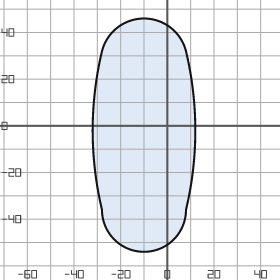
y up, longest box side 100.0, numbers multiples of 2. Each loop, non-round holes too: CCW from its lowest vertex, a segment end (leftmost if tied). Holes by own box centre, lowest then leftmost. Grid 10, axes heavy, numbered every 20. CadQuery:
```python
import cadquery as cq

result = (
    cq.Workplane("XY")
    .moveTo(-28.0, -36.0)
    .threePointArc((-10.0, -54.0), (8.0, -36.0))
    .threePointArc((12.0, -2.0), (8.0, 32.0))
    .threePointArc((-10.0, 46.0), (-28.0, 32.0))
    .threePointArc((-32.0, -2.0), (-28.0, -36.0))
    .close()
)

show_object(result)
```